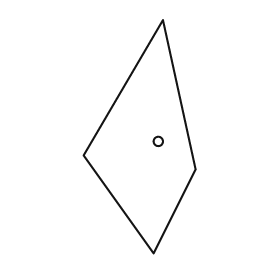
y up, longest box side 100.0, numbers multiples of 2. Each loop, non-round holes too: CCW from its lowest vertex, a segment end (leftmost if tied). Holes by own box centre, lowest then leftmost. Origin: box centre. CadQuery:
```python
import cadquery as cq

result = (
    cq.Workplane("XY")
    .moveTo(6.0, -50.0)
    .lineTo(24.0, -14.0)
    .lineTo(10.0, 50.0)
    .lineTo(-24.0, -8.0)
    .close()
    .moveTo(8.0, -2.0)
    .circle(2.0)
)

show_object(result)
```